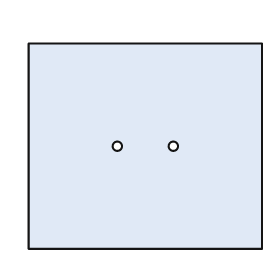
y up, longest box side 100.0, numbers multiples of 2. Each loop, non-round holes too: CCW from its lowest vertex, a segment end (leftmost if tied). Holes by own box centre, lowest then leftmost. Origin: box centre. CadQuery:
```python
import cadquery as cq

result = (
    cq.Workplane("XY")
    .moveTo(-50.0, -44.0)
    .lineTo(50.0, -44.0)
    .lineTo(50.0, 44.0)
    .lineTo(-50.0, 44.0)
    .close()
    .moveTo(-12.0, 0.0)
    .circle(2.0)
    .moveTo(12.0, 0.0)
    .circle(2.0)
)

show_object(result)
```